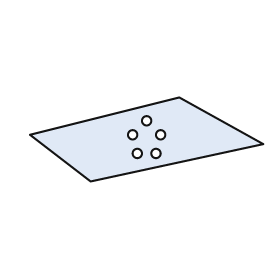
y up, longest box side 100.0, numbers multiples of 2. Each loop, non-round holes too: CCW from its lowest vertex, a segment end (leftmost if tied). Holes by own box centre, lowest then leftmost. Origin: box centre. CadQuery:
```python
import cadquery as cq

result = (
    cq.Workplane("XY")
    .moveTo(-24.0, -18.0)
    .lineTo(50.0, -2.0)
    .lineTo(14.0, 18.0)
    .lineTo(-50.0, 2.0)
    .close()
    .moveTo(-4.0, -6.0)
    .circle(2.0)
    .moveTo(4.0, -6.0)
    .circle(2.0)
    .moveTo(-6.0, 2.0)
    .circle(2.0)
    .moveTo(6.0, 2.0)
    .circle(2.0)
    .moveTo(0.0, 8.0)
    .circle(2.0)
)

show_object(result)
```